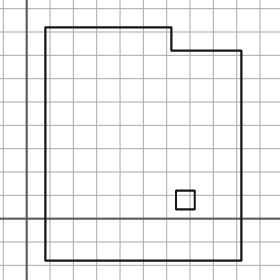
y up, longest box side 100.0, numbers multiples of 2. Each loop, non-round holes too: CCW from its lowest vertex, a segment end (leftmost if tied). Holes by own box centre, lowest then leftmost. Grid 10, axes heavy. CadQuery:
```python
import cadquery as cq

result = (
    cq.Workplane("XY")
    .moveTo(8.0, -18.0)
    .lineTo(92.0, -18.0)
    .lineTo(92.0, 72.0)
    .lineTo(62.0, 72.0)
    .lineTo(62.0, 82.0)
    .lineTo(8.0, 82.0)
    .close()
    .moveTo(64.0, 4.0)
    .lineTo(72.0, 4.0)
    .lineTo(72.0, 12.0)
    .lineTo(64.0, 12.0)
    .close()
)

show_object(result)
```